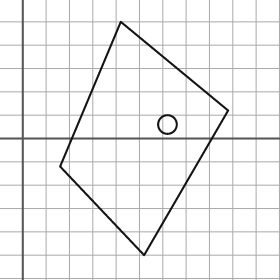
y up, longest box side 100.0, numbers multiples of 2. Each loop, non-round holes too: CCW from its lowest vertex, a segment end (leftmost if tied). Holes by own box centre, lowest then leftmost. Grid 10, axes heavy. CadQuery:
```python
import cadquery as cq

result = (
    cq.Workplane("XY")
    .moveTo(52.0, -50.0)
    .lineTo(88.0, 12.0)
    .lineTo(42.0, 50.0)
    .lineTo(16.0, -12.0)
    .close()
    .moveTo(62.0, 6.0)
    .circle(4.0)
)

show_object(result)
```